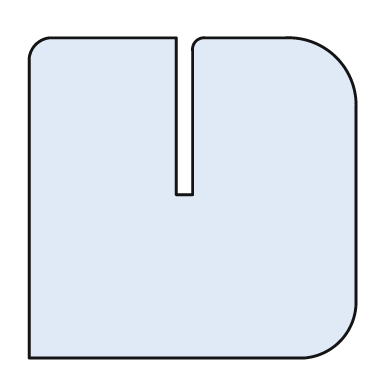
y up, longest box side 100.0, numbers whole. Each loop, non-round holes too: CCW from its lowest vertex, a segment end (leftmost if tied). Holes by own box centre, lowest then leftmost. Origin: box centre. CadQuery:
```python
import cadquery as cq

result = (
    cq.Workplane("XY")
    .moveTo(-50.0, -49.0)
    .lineTo(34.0, -49.0)
    .threePointArc((45.0, -44.0), (50.0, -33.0))
    .lineTo(50.0, 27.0)
    .threePointArc((44.0, 43.0), (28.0, 49.0))
    .lineTo(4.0, 49.0)
    .threePointArc((1.0, 48.0), (0.0, 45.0))
    .lineTo(0.0, 1.0)
    .lineTo(-5.0, 1.0)
    .lineTo(-5.0, 49.0)
    .lineTo(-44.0, 49.0)
    .threePointArc((-48.0, 47.0), (-50.0, 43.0))
    .close()
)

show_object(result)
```